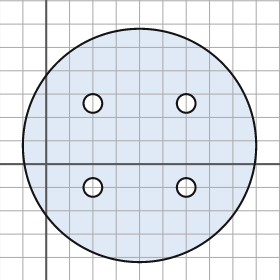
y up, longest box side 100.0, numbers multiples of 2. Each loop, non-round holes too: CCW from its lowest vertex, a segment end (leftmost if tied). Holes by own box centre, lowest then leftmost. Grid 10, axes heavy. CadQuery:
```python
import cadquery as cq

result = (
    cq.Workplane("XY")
    .moveTo(40.0, 8.0)
    .circle(50.0)
    .moveTo(20.0, -10.0)
    .circle(4.0)
    .moveTo(60.0, -10.0)
    .circle(4.0)
    .moveTo(20.0, 26.0)
    .circle(4.0)
    .moveTo(60.0, 26.0)
    .circle(4.0)
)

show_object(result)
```